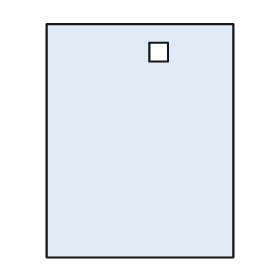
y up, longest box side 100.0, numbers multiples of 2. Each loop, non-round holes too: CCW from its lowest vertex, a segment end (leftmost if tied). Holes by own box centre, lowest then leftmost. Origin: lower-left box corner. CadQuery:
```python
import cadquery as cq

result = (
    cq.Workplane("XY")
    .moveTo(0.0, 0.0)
    .lineTo(80.0, 0.0)
    .lineTo(80.0, 100.0)
    .lineTo(0.0, 100.0)
    .close()
    .moveTo(44.0, 84.0)
    .lineTo(52.0, 84.0)
    .lineTo(52.0, 92.0)
    .lineTo(44.0, 92.0)
    .close()
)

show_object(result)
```